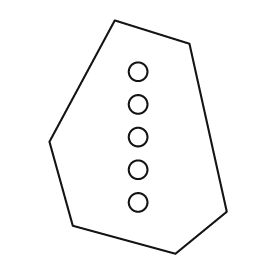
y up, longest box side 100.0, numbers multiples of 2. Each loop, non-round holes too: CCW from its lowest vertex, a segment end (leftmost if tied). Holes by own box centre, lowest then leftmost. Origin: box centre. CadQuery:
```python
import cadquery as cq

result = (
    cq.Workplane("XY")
    .moveTo(16.0, -50.0)
    .lineTo(38.0, -32.0)
    .lineTo(22.0, 40.0)
    .lineTo(-10.0, 50.0)
    .lineTo(-38.0, -2.0)
    .lineTo(-28.0, -38.0)
    .close()
    .moveTo(0.0, -28.0)
    .circle(4.0)
    .moveTo(0.0, -14.0)
    .circle(4.0)
    .moveTo(0.0, 0.0)
    .circle(4.0)
    .moveTo(0.0, 14.0)
    .circle(4.0)
    .moveTo(0.0, 28.0)
    .circle(4.0)
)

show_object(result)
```